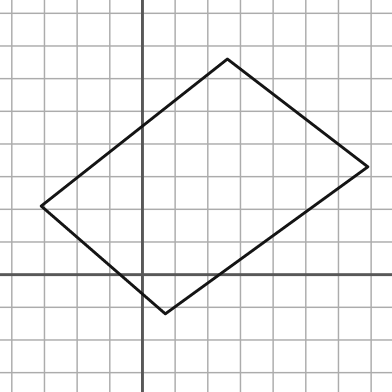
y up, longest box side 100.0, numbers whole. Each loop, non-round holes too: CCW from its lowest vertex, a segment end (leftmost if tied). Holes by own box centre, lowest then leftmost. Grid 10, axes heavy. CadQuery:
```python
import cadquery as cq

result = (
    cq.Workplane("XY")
    .moveTo(7.0, -12.0)
    .lineTo(69.0, 33.0)
    .lineTo(26.0, 66.0)
    .lineTo(-31.0, 21.0)
    .close()
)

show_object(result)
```